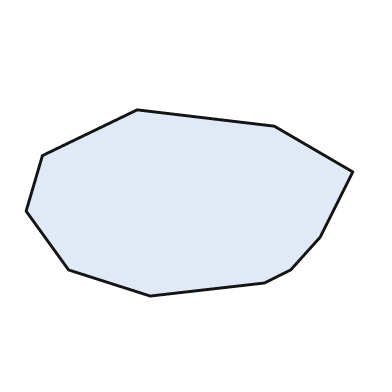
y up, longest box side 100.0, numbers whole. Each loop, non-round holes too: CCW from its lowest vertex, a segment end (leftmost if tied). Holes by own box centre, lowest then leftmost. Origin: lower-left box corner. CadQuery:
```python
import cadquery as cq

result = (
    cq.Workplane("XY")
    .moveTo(38.0, 0.0)
    .lineTo(73.0, 4.0)
    .lineTo(81.0, 8.0)
    .lineTo(90.0, 18.0)
    .lineTo(100.0, 38.0)
    .lineTo(76.0, 52.0)
    .lineTo(34.0, 57.0)
    .lineTo(5.0, 43.0)
    .lineTo(0.0, 26.0)
    .lineTo(13.0, 8.0)
    .close()
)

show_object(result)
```